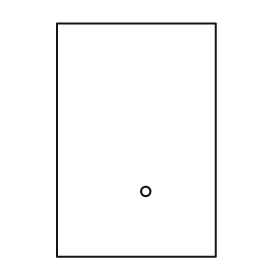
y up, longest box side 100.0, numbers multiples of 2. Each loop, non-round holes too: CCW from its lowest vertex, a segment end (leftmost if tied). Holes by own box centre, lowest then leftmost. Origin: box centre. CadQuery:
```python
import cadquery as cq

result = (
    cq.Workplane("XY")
    .moveTo(-34.0, -50.0)
    .lineTo(34.0, -50.0)
    .lineTo(34.0, 50.0)
    .lineTo(-34.0, 50.0)
    .close()
    .moveTo(4.0, -22.0)
    .circle(2.0)
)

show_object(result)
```